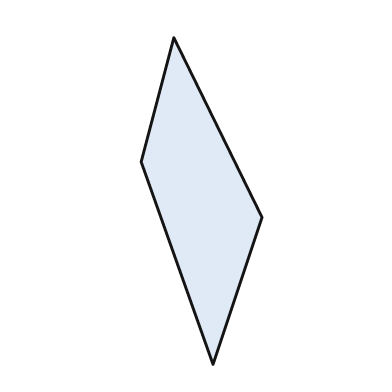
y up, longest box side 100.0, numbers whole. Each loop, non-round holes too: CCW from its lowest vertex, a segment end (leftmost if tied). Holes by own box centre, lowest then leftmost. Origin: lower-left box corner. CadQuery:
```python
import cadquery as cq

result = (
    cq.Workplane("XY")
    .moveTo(22.0, 0.0)
    .lineTo(37.0, 45.0)
    .lineTo(10.0, 100.0)
    .lineTo(0.0, 62.0)
    .close()
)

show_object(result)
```